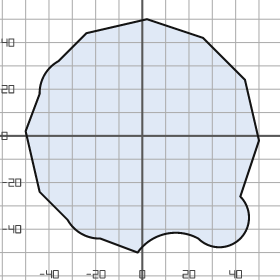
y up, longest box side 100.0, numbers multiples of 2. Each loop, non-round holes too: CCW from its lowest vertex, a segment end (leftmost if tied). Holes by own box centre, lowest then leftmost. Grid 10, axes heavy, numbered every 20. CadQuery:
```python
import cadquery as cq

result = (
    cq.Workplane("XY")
    .moveTo(-2.0, -50.0)
    .threePointArc((10.0, -42.0), (24.0, -44.0))
    .threePointArc((42.0, -44.0), (42.0, -26.0))
    .lineTo(50.0, -2.0)
    .lineTo(44.0, 24.0)
    .lineTo(26.0, 42.0)
    .lineTo(2.0, 50.0)
    .lineTo(-24.0, 44.0)
    .lineTo(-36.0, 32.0)
    .threePointArc((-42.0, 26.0), (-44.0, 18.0))
    .lineTo(-50.0, 2.0)
    .lineTo(-44.0, -24.0)
    .lineTo(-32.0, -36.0)
    .threePointArc((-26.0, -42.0), (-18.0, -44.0))
    .close()
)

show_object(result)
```